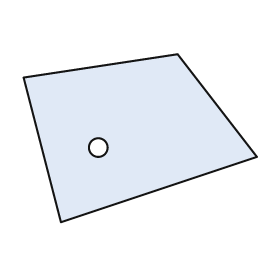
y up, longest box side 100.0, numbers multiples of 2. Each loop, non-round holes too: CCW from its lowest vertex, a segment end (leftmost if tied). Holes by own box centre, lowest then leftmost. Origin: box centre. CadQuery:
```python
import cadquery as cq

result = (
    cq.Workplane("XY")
    .moveTo(-34.0, -36.0)
    .lineTo(50.0, -8.0)
    .lineTo(16.0, 36.0)
    .lineTo(-50.0, 26.0)
    .close()
    .moveTo(-18.0, -4.0)
    .circle(4.0)
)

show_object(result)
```